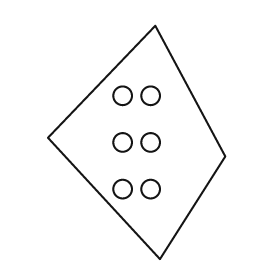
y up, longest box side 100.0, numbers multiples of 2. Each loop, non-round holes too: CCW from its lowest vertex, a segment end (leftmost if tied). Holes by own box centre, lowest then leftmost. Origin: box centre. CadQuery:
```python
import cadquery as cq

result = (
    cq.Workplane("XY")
    .moveTo(10.0, -50.0)
    .lineTo(38.0, -6.0)
    .lineTo(8.0, 50.0)
    .lineTo(-38.0, 2.0)
    .close()
    .moveTo(-6.0, -20.0)
    .circle(4.0)
    .moveTo(6.0, -20.0)
    .circle(4.0)
    .moveTo(-6.0, 0.0)
    .circle(4.0)
    .moveTo(6.0, 0.0)
    .circle(4.0)
    .moveTo(-6.0, 20.0)
    .circle(4.0)
    .moveTo(6.0, 20.0)
    .circle(4.0)
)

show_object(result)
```